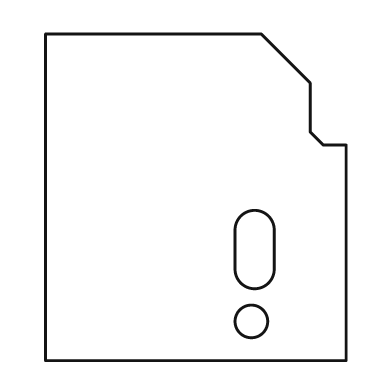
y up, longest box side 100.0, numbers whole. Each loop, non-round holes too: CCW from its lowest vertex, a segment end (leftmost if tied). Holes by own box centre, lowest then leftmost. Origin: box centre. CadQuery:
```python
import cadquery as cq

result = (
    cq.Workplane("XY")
    .moveTo(-46.0, -50.0)
    .lineTo(46.0, -50.0)
    .lineTo(46.0, 16.0)
    .lineTo(39.0, 16.0)
    .lineTo(35.0, 20.0)
    .lineTo(35.0, 35.0)
    .lineTo(20.0, 50.0)
    .lineTo(-46.0, 50.0)
    .close()
    .moveTo(17.0, -38.0)
    .circle(5.0)
    .moveTo(12.0, -22.0)
    .threePointArc((18.0, -28.0), (24.0, -22.0))
    .lineTo(24.0, -10.0)
    .threePointArc((18.0, -4.0), (12.0, -10.0))
    .close()
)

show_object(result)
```